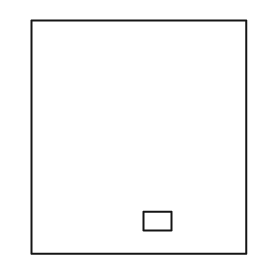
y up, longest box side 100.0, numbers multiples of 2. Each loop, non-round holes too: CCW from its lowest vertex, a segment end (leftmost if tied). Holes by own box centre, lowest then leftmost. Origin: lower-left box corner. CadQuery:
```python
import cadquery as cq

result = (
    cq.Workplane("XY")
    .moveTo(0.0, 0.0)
    .lineTo(92.0, 0.0)
    .lineTo(92.0, 100.0)
    .lineTo(0.0, 100.0)
    .close()
    .moveTo(48.0, 10.0)
    .lineTo(60.0, 10.0)
    .lineTo(60.0, 18.0)
    .lineTo(48.0, 18.0)
    .close()
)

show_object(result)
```